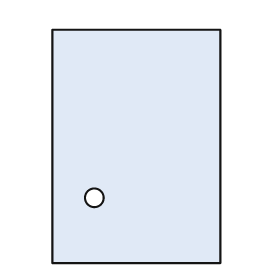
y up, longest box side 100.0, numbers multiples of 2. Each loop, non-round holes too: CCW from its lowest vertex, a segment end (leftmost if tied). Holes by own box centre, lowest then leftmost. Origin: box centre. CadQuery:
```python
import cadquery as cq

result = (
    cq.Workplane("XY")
    .moveTo(-36.0, -50.0)
    .lineTo(36.0, -50.0)
    .lineTo(36.0, 50.0)
    .lineTo(-36.0, 50.0)
    .close()
    .moveTo(-18.0, -22.0)
    .circle(4.0)
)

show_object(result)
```